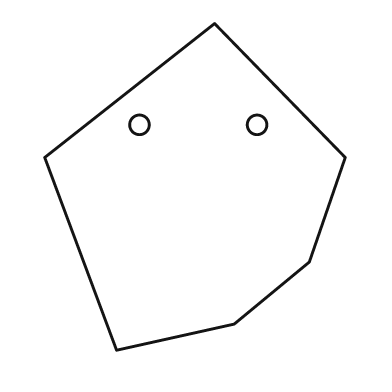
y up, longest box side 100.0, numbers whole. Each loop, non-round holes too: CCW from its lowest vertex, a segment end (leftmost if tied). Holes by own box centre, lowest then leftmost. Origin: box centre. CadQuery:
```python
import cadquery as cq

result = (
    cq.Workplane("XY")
    .moveTo(-24.0, -50.0)
    .lineTo(12.0, -42.0)
    .lineTo(35.0, -23.0)
    .lineTo(46.0, 9.0)
    .lineTo(6.0, 50.0)
    .lineTo(-46.0, 9.0)
    .close()
    .moveTo(-17.0, 19.0)
    .circle(3.0)
    .moveTo(19.0, 19.0)
    .circle(3.0)
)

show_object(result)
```